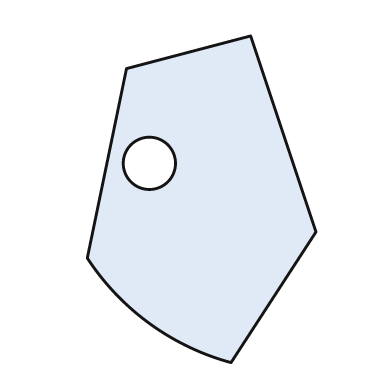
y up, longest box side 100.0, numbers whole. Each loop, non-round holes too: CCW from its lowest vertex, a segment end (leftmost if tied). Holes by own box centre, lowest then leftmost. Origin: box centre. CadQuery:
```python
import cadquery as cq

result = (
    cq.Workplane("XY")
    .moveTo(9.0, -50.0)
    .lineTo(35.0, -10.0)
    .lineTo(15.0, 50.0)
    .lineTo(-23.0, 40.0)
    .lineTo(-35.0, -18.0)
    .threePointArc((-16.0, -38.0), (9.0, -50.0))
    .close()
    .moveTo(-16.0, 11.0)
    .circle(8.0)
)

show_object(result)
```